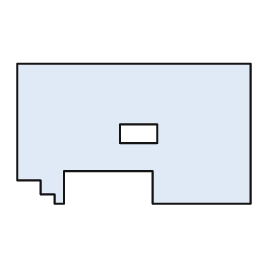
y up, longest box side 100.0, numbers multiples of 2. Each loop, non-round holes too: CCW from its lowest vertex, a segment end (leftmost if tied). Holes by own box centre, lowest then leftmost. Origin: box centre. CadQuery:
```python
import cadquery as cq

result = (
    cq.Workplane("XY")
    .moveTo(-34.0, -30.0)
    .lineTo(-30.0, -30.0)
    .lineTo(-30.0, -16.0)
    .lineTo(8.0, -16.0)
    .lineTo(8.0, -30.0)
    .lineTo(50.0, -30.0)
    .lineTo(50.0, 30.0)
    .lineTo(-50.0, 30.0)
    .lineTo(-50.0, -20.0)
    .lineTo(-40.0, -20.0)
    .lineTo(-40.0, -26.0)
    .lineTo(-34.0, -26.0)
    .close()
    .moveTo(-6.0, -4.0)
    .lineTo(10.0, -4.0)
    .lineTo(10.0, 4.0)
    .lineTo(-6.0, 4.0)
    .close()
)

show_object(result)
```